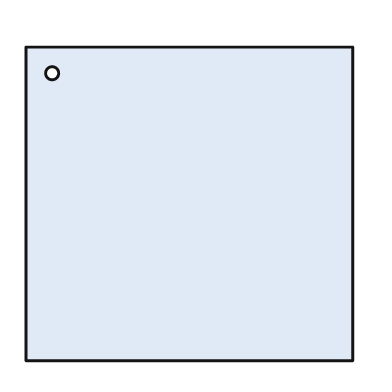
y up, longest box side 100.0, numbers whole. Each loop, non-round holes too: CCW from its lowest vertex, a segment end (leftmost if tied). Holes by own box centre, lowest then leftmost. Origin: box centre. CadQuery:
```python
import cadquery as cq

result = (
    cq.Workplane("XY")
    .moveTo(-50.0, -48.0)
    .lineTo(50.0, -48.0)
    .lineTo(50.0, 48.0)
    .lineTo(-50.0, 48.0)
    .close()
    .moveTo(-42.0, 40.0)
    .circle(2.0)
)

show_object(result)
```